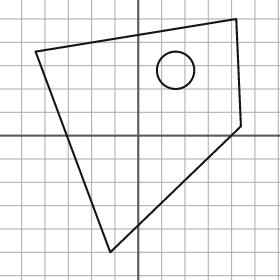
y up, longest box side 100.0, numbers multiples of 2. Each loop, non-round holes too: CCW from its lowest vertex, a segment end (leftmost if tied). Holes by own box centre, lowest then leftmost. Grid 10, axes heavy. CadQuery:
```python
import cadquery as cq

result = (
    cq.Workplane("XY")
    .moveTo(-12.0, -50.0)
    .lineTo(44.0, 4.0)
    .lineTo(42.0, 50.0)
    .lineTo(-44.0, 36.0)
    .close()
    .moveTo(16.0, 28.0)
    .circle(8.0)
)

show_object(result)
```